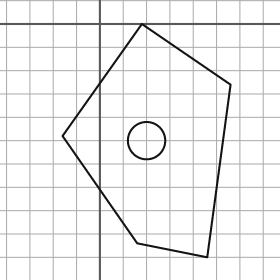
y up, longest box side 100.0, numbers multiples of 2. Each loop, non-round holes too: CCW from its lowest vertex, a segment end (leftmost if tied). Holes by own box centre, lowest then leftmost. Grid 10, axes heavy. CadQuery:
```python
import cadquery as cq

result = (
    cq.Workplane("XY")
    .moveTo(46.0, -100.0)
    .lineTo(56.0, -26.0)
    .lineTo(18.0, 0.0)
    .lineTo(-16.0, -48.0)
    .lineTo(16.0, -94.0)
    .close()
    .moveTo(20.0, -50.0)
    .circle(8.0)
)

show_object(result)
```